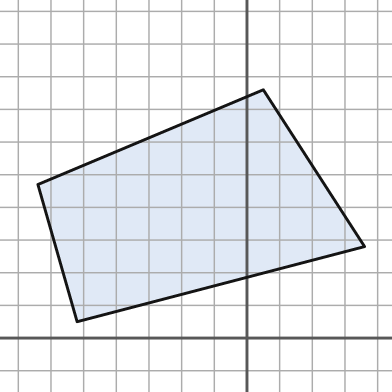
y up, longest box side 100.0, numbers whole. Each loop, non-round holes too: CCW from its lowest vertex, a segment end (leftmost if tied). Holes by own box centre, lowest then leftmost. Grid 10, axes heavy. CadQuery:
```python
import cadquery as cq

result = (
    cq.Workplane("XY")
    .moveTo(-52.0, 5.0)
    .lineTo(36.0, 28.0)
    .lineTo(5.0, 76.0)
    .lineTo(-64.0, 47.0)
    .close()
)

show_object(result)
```